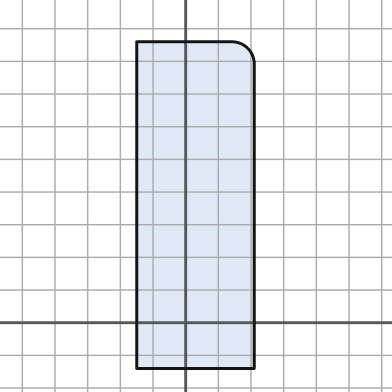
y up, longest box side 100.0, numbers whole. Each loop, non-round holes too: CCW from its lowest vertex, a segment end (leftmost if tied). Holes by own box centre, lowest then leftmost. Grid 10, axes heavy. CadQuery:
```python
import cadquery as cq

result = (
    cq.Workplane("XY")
    .moveTo(-15.0, -14.0)
    .lineTo(21.0, -14.0)
    .lineTo(21.0, 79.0)
    .threePointArc((19.0, 84.0), (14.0, 86.0))
    .lineTo(-15.0, 86.0)
    .close()
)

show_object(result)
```